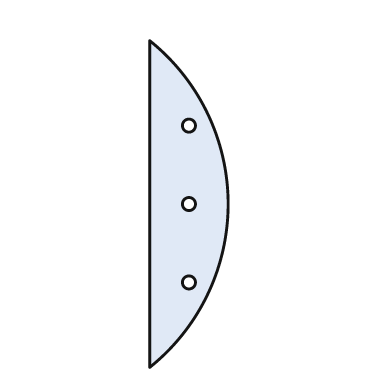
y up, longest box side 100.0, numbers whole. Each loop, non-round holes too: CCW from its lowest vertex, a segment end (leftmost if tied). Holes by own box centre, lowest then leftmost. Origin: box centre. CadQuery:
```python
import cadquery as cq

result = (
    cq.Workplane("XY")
    .moveTo(-12.0, -50.0)
    .threePointArc((12.0, 0.0), (-12.0, 50.0))
    .close()
    .moveTo(0.0, -24.0)
    .circle(2.0)
    .moveTo(0.0, 0.0)
    .circle(2.0)
    .moveTo(0.0, 24.0)
    .circle(2.0)
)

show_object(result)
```